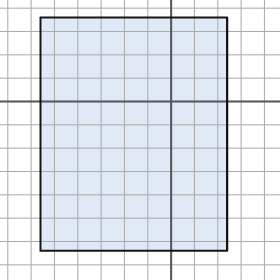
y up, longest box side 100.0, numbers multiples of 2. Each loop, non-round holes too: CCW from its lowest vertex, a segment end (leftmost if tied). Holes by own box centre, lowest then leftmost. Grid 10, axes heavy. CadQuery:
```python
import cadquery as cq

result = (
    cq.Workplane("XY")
    .moveTo(-56.0, -64.0)
    .lineTo(24.0, -64.0)
    .lineTo(24.0, 36.0)
    .lineTo(-56.0, 36.0)
    .close()
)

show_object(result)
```